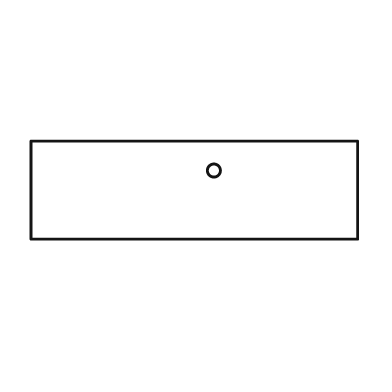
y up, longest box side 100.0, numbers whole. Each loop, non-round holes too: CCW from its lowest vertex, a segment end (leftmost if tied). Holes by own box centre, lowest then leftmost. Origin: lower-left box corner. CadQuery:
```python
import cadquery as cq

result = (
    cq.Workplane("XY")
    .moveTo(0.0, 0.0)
    .lineTo(100.0, 0.0)
    .lineTo(100.0, 30.0)
    .lineTo(0.0, 30.0)
    .close()
    .moveTo(56.0, 21.0)
    .circle(2.0)
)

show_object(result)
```